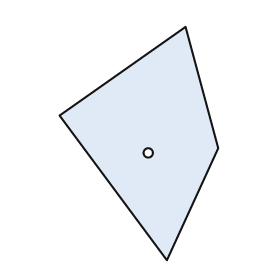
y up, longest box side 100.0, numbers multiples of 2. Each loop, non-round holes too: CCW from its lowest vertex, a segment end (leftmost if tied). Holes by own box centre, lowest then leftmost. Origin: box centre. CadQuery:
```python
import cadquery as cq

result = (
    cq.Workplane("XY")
    .moveTo(12.0, -50.0)
    .lineTo(34.0, -2.0)
    .lineTo(20.0, 50.0)
    .lineTo(-34.0, 12.0)
    .close()
    .moveTo(4.0, -4.0)
    .circle(2.0)
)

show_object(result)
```